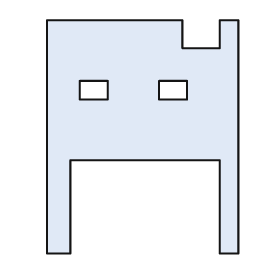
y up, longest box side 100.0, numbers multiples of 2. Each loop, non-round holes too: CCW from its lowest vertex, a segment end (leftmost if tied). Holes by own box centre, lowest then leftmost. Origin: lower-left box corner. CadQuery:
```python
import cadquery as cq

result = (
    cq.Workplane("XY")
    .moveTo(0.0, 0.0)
    .lineTo(10.0, 0.0)
    .lineTo(10.0, 40.0)
    .lineTo(74.0, 40.0)
    .lineTo(74.0, 0.0)
    .lineTo(82.0, 0.0)
    .lineTo(82.0, 100.0)
    .lineTo(74.0, 100.0)
    .lineTo(74.0, 88.0)
    .lineTo(58.0, 88.0)
    .lineTo(58.0, 100.0)
    .lineTo(0.0, 100.0)
    .close()
    .moveTo(14.0, 66.0)
    .lineTo(26.0, 66.0)
    .lineTo(26.0, 74.0)
    .lineTo(14.0, 74.0)
    .close()
    .moveTo(48.0, 66.0)
    .lineTo(60.0, 66.0)
    .lineTo(60.0, 74.0)
    .lineTo(48.0, 74.0)
    .close()
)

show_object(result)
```